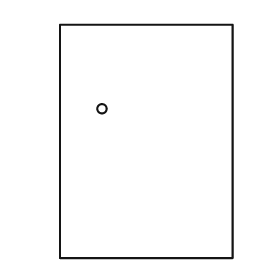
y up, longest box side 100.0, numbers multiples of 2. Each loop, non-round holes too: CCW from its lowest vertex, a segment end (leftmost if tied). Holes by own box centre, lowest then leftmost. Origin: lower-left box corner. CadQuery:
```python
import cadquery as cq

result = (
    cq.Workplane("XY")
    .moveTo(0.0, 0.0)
    .lineTo(74.0, 0.0)
    .lineTo(74.0, 100.0)
    .lineTo(0.0, 100.0)
    .close()
    .moveTo(18.0, 64.0)
    .circle(2.0)
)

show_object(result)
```